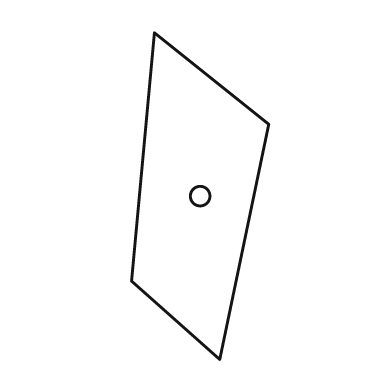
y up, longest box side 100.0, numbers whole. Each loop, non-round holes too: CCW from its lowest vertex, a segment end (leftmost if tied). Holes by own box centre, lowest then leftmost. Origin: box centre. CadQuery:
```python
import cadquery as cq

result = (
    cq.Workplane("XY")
    .moveTo(6.0, -50.0)
    .lineTo(21.0, 22.0)
    .lineTo(-14.0, 50.0)
    .lineTo(-21.0, -26.0)
    .close()
    .moveTo(0.0, 0.0)
    .circle(3.0)
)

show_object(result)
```